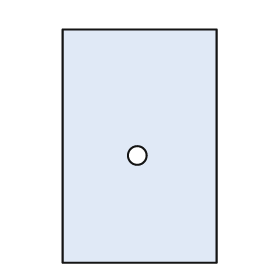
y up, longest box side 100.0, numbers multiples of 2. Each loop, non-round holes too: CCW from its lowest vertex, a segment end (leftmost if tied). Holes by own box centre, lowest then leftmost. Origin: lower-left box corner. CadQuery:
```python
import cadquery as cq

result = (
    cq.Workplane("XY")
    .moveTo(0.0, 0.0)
    .lineTo(66.0, 0.0)
    .lineTo(66.0, 100.0)
    .lineTo(0.0, 100.0)
    .close()
    .moveTo(32.0, 46.0)
    .circle(4.0)
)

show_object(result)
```